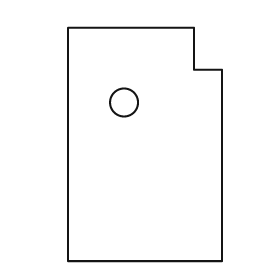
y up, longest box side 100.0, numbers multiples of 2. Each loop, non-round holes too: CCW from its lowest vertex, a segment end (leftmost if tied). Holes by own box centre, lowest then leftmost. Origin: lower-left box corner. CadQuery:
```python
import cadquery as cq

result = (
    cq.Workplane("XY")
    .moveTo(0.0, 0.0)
    .lineTo(66.0, 0.0)
    .lineTo(66.0, 82.0)
    .lineTo(54.0, 82.0)
    .lineTo(54.0, 100.0)
    .lineTo(0.0, 100.0)
    .close()
    .moveTo(24.0, 68.0)
    .circle(6.0)
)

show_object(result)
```